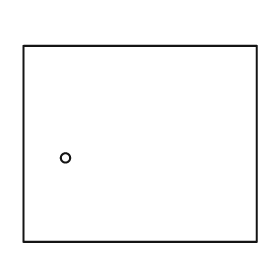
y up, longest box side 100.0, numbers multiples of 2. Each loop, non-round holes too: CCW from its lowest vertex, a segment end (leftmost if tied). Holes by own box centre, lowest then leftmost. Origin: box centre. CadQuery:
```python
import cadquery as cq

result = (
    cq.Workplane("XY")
    .moveTo(-50.0, -42.0)
    .lineTo(50.0, -42.0)
    .lineTo(50.0, 42.0)
    .lineTo(-50.0, 42.0)
    .close()
    .moveTo(-32.0, -6.0)
    .circle(2.0)
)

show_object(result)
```